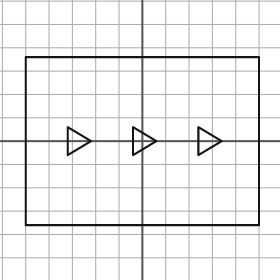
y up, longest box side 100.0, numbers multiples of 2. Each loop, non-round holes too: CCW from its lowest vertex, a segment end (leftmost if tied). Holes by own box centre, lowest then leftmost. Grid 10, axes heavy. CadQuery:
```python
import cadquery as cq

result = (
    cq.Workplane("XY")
    .moveTo(-50.0, -36.0)
    .lineTo(50.0, -36.0)
    .lineTo(50.0, 36.0)
    .lineTo(-50.0, 36.0)
    .close()
    .moveTo(-32.0, -6.0)
    .lineTo(-22.0, 0.0)
    .lineTo(-32.0, 6.0)
    .close()
    .moveTo(-4.0, -6.0)
    .lineTo(6.0, 0.0)
    .lineTo(-4.0, 6.0)
    .close()
    .moveTo(24.0, -6.0)
    .lineTo(34.0, 0.0)
    .lineTo(24.0, 6.0)
    .close()
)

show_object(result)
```